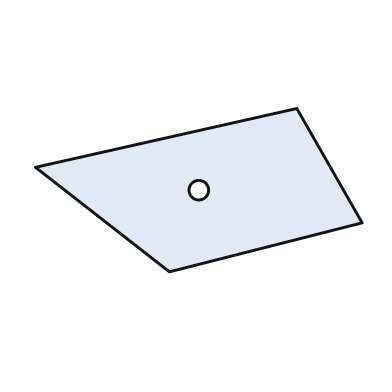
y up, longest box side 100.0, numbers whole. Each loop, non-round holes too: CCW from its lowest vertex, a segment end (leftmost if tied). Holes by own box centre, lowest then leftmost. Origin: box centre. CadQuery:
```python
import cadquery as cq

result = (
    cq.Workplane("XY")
    .moveTo(-9.0, -25.0)
    .lineTo(50.0, -10.0)
    .lineTo(30.0, 25.0)
    .lineTo(-50.0, 7.0)
    .close()
    .moveTo(0.0, 0.0)
    .circle(3.0)
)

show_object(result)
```